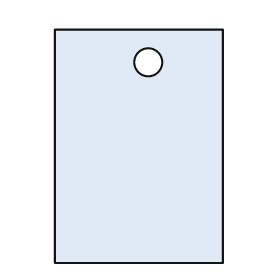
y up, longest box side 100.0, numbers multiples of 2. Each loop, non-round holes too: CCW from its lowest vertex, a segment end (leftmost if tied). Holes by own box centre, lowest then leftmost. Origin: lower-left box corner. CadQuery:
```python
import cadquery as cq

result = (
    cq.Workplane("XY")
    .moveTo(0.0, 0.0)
    .lineTo(72.0, 0.0)
    .lineTo(72.0, 100.0)
    .lineTo(0.0, 100.0)
    .close()
    .moveTo(40.0, 86.0)
    .circle(6.0)
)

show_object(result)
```